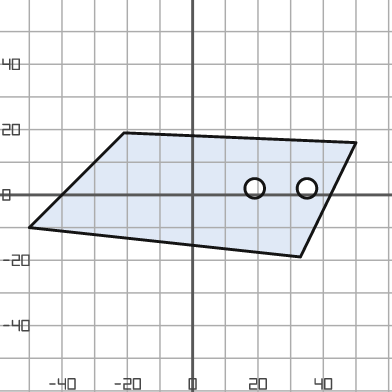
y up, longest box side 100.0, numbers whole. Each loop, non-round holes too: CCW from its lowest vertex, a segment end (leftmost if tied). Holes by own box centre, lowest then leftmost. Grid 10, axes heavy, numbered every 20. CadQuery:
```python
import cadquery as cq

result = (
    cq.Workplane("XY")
    .moveTo(33.0, -19.0)
    .lineTo(50.0, 16.0)
    .lineTo(-21.0, 19.0)
    .lineTo(-50.0, -10.0)
    .close()
    .moveTo(19.0, 2.0)
    .circle(3.0)
    .moveTo(35.0, 2.0)
    .circle(3.0)
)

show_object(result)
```